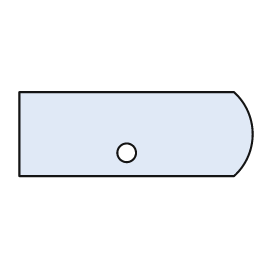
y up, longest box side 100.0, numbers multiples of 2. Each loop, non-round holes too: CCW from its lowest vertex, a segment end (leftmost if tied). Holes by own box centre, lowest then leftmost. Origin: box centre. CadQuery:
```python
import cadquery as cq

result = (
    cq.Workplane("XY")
    .moveTo(-50.0, -18.0)
    .lineTo(42.0, -18.0)
    .threePointArc((50.0, 0.0), (42.0, 18.0))
    .lineTo(-50.0, 18.0)
    .close()
    .moveTo(-4.0, -8.0)
    .circle(4.0)
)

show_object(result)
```